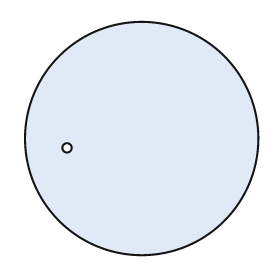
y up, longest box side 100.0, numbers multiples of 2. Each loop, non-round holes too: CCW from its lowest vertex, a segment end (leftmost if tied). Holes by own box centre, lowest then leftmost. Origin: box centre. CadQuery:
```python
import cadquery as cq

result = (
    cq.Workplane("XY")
    .moveTo(0.0, 0.0)
    .circle(50.0)
    .moveTo(-32.0, -4.0)
    .circle(2.0)
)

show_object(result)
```